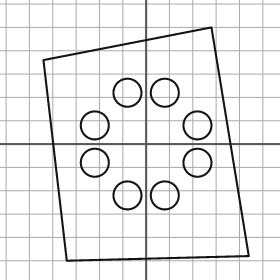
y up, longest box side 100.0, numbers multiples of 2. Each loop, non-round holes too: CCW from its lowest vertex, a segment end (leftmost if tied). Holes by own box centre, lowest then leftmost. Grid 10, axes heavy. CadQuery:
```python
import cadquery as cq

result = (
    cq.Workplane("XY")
    .moveTo(-34.0, -50.0)
    .lineTo(44.0, -48.0)
    .lineTo(28.0, 50.0)
    .lineTo(-44.0, 36.0)
    .close()
    .moveTo(-8.0, -22.0)
    .circle(6.0)
    .moveTo(8.0, -22.0)
    .circle(6.0)
    .moveTo(-22.0, -8.0)
    .circle(6.0)
    .moveTo(22.0, -8.0)
    .circle(6.0)
    .moveTo(-22.0, 8.0)
    .circle(6.0)
    .moveTo(22.0, 8.0)
    .circle(6.0)
    .moveTo(-8.0, 22.0)
    .circle(6.0)
    .moveTo(8.0, 22.0)
    .circle(6.0)
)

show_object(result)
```